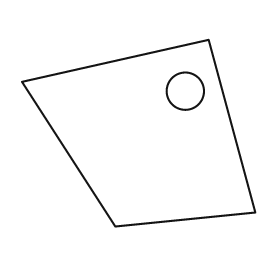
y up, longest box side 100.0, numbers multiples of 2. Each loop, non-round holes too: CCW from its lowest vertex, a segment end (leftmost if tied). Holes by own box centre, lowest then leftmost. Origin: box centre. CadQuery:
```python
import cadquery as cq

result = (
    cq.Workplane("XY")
    .moveTo(-10.0, -40.0)
    .lineTo(50.0, -34.0)
    .lineTo(30.0, 40.0)
    .lineTo(-50.0, 22.0)
    .close()
    .moveTo(20.0, 18.0)
    .circle(8.0)
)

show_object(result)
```